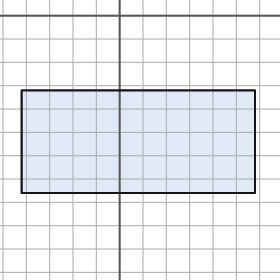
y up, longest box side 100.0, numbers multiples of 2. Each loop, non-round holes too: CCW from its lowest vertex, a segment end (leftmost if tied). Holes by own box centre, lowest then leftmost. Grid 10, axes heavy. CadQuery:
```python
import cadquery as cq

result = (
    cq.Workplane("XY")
    .moveTo(-42.0, -76.0)
    .lineTo(58.0, -76.0)
    .lineTo(58.0, -32.0)
    .lineTo(-42.0, -32.0)
    .close()
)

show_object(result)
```